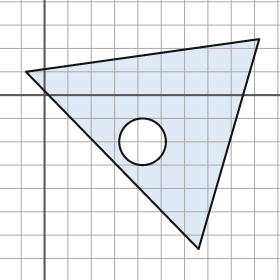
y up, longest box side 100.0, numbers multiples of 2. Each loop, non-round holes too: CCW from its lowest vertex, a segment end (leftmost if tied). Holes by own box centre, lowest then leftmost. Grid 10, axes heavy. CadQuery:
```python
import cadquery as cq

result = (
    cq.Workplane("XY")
    .moveTo(66.0, -66.0)
    .lineTo(92.0, 24.0)
    .lineTo(-8.0, 10.0)
    .close()
    .moveTo(42.0, -20.0)
    .circle(10.0)
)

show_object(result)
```